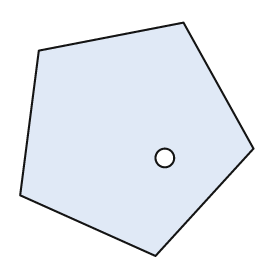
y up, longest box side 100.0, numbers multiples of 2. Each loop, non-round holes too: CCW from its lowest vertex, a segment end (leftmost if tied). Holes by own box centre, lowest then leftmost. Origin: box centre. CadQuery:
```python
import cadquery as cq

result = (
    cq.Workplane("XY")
    .moveTo(8.0, -50.0)
    .lineTo(50.0, -4.0)
    .lineTo(20.0, 50.0)
    .lineTo(-42.0, 38.0)
    .lineTo(-50.0, -24.0)
    .close()
    .moveTo(12.0, -8.0)
    .circle(4.0)
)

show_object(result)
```